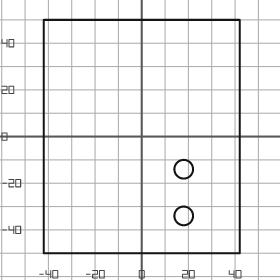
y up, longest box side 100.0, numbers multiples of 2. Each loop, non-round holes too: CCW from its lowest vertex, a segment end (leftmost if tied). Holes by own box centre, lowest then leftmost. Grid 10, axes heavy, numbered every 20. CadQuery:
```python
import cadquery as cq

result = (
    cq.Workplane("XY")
    .moveTo(-42.0, -50.0)
    .lineTo(42.0, -50.0)
    .lineTo(42.0, 50.0)
    .lineTo(-42.0, 50.0)
    .close()
    .moveTo(18.0, -34.0)
    .circle(4.0)
    .moveTo(18.0, -14.0)
    .circle(4.0)
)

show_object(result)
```